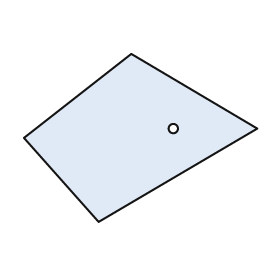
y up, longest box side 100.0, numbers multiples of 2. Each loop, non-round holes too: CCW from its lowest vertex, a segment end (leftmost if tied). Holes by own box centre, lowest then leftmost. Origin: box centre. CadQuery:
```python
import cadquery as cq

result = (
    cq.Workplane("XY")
    .moveTo(-18.0, -36.0)
    .lineTo(50.0, 4.0)
    .lineTo(-4.0, 36.0)
    .lineTo(-50.0, 0.0)
    .close()
    .moveTo(14.0, 4.0)
    .circle(2.0)
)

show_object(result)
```